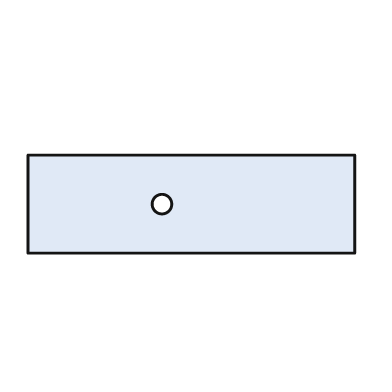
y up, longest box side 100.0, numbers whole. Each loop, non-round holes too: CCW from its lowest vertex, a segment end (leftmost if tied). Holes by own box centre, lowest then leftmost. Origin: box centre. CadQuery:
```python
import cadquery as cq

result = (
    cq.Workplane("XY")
    .moveTo(-50.0, -15.0)
    .lineTo(50.0, -15.0)
    .lineTo(50.0, 15.0)
    .lineTo(-50.0, 15.0)
    .close()
    .moveTo(-9.0, 0.0)
    .circle(3.0)
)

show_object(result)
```